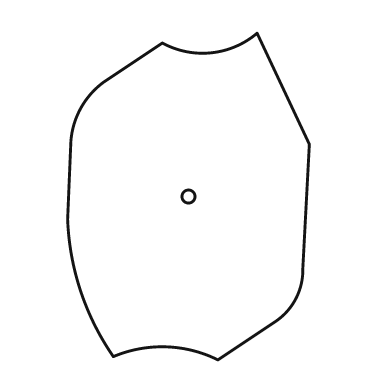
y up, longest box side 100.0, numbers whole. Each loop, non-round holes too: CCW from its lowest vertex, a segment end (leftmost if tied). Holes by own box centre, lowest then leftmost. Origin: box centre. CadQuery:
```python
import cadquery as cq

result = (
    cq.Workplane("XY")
    .moveTo(9.0, -50.0)
    .lineTo(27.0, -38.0)
    .threePointArc((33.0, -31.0), (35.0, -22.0))
    .lineTo(37.0, 16.0)
    .lineTo(21.0, 50.0)
    .threePointArc((7.0, 44.0), (-8.0, 47.0))
    .lineTo(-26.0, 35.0)
    .threePointArc((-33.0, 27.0), (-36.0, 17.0))
    .lineTo(-37.0, -7.0)
    .threePointArc((-33.0, -29.0), (-23.0, -49.0))
    .threePointArc((-7.0, -46.0), (9.0, -50.0))
    .close()
    .moveTo(0.0, 0.0)
    .circle(2.0)
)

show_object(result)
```